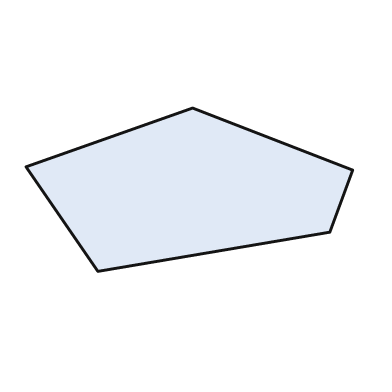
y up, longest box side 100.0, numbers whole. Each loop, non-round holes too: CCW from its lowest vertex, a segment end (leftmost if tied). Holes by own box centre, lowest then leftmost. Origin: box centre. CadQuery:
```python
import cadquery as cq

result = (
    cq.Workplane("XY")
    .moveTo(-28.0, -25.0)
    .lineTo(43.0, -13.0)
    .lineTo(50.0, 6.0)
    .lineTo(1.0, 25.0)
    .lineTo(-50.0, 7.0)
    .close()
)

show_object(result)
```